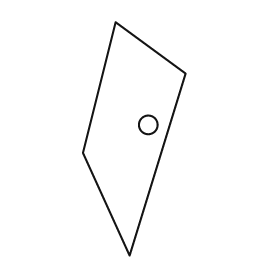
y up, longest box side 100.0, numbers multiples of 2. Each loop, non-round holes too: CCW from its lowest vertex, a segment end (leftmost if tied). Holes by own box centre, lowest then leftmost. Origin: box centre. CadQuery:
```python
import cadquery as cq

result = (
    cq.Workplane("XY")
    .moveTo(-2.0, -50.0)
    .lineTo(22.0, 28.0)
    .lineTo(-8.0, 50.0)
    .lineTo(-22.0, -6.0)
    .close()
    .moveTo(6.0, 6.0)
    .circle(4.0)
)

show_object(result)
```